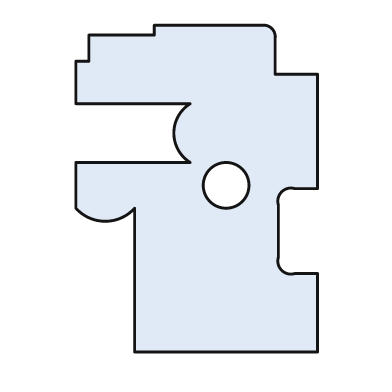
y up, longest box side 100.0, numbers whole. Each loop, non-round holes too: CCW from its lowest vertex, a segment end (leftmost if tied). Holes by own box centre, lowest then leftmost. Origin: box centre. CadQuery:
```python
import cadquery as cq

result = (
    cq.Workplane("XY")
    .moveTo(-19.0, -50.0)
    .lineTo(37.0, -50.0)
    .lineTo(37.0, -26.0)
    .lineTo(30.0, -26.0)
    .threePointArc((26.0, -25.0), (25.0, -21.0))
    .lineTo(25.0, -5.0)
    .threePointArc((26.0, -1.0), (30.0, 0.0))
    .lineTo(37.0, 0.0)
    .lineTo(37.0, 35.0)
    .lineTo(24.0, 35.0)
    .lineTo(24.0, 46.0)
    .threePointArc((23.0, 49.0), (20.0, 50.0))
    .lineTo(-13.0, 50.0)
    .lineTo(-13.0, 47.0)
    .lineTo(-33.0, 47.0)
    .lineTo(-33.0, 39.0)
    .lineTo(-37.0, 39.0)
    .lineTo(-37.0, 26.0)
    .lineTo(-2.0, 26.0)
    .threePointArc((-7.0, 17.0), (-2.0, 8.0))
    .lineTo(-37.0, 8.0)
    .lineTo(-37.0, -6.0)
    .threePointArc((-28.0, -10.0), (-19.0, -6.0))
    .close()
    .moveTo(9.0, 1.0)
    .circle(7.0)
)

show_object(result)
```